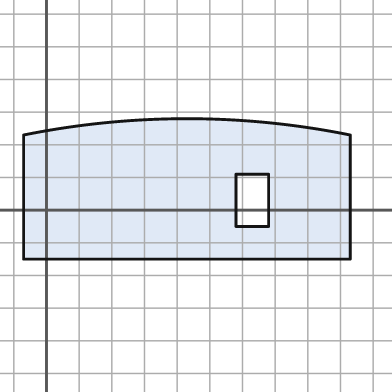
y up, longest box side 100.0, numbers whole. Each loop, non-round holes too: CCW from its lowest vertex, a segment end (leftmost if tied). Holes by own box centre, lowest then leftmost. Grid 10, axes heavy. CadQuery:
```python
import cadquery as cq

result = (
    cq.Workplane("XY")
    .moveTo(-7.0, -15.0)
    .lineTo(93.0, -15.0)
    .lineTo(93.0, 23.0)
    .threePointArc((43.0, 28.0), (-7.0, 23.0))
    .close()
    .moveTo(58.0, -5.0)
    .lineTo(68.0, -5.0)
    .lineTo(68.0, 11.0)
    .lineTo(58.0, 11.0)
    .close()
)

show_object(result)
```